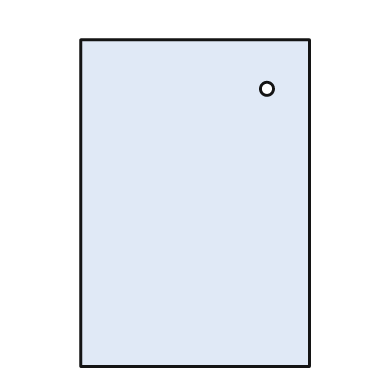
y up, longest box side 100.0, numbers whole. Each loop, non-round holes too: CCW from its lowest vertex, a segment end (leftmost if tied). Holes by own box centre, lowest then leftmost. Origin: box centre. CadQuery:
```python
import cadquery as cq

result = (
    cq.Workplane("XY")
    .moveTo(-35.0, -50.0)
    .lineTo(35.0, -50.0)
    .lineTo(35.0, 50.0)
    .lineTo(-35.0, 50.0)
    .close()
    .moveTo(22.0, 35.0)
    .circle(2.0)
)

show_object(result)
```